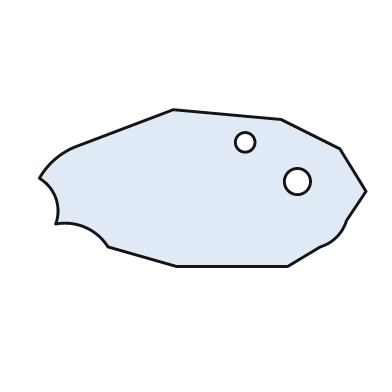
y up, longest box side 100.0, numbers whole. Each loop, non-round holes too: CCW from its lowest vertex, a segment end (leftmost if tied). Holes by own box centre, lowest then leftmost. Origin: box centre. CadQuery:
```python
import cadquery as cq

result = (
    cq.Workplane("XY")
    .moveTo(-8.0, -24.0)
    .lineTo(26.0, -24.0)
    .lineTo(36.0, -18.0)
    .threePointArc((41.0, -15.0), (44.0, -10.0))
    .lineTo(50.0, -1.0)
    .lineTo(42.0, 12.0)
    .lineTo(24.0, 21.0)
    .lineTo(-9.0, 24.0)
    .lineTo(-38.0, 13.0)
    .threePointArc((-45.0, 9.0), (-50.0, 3.0))
    .threePointArc((-45.0, -3.0), (-45.0, -11.0))
    .threePointArc((-36.0, -12.0), (-29.0, -18.0))
    .close()
    .moveTo(29.0, 2.0)
    .circle(4.0)
    .moveTo(13.0, 14.0)
    .circle(3.0)
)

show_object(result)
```